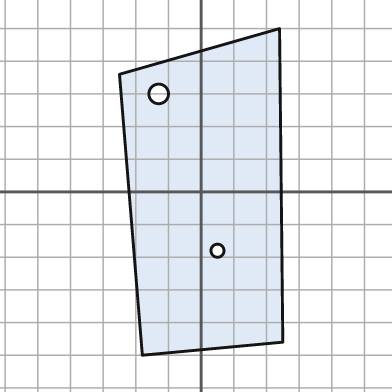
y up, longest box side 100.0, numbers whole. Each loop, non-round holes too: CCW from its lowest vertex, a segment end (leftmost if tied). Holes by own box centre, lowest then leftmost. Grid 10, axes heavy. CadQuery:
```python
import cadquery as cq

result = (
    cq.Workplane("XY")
    .moveTo(-18.0, -50.0)
    .lineTo(25.0, -46.0)
    .lineTo(24.0, 50.0)
    .lineTo(-25.0, 36.0)
    .close()
    .moveTo(5.0, -18.0)
    .circle(2.0)
    .moveTo(-13.0, 30.0)
    .circle(3.0)
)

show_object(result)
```